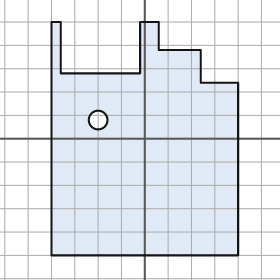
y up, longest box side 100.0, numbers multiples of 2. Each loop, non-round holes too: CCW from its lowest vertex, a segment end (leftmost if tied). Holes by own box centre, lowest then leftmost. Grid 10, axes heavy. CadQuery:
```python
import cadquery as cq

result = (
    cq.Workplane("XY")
    .moveTo(-40.0, -50.0)
    .lineTo(40.0, -50.0)
    .lineTo(40.0, 24.0)
    .lineTo(24.0, 24.0)
    .lineTo(24.0, 38.0)
    .lineTo(6.0, 38.0)
    .lineTo(6.0, 50.0)
    .lineTo(-2.0, 50.0)
    .lineTo(-2.0, 28.0)
    .lineTo(-36.0, 28.0)
    .lineTo(-36.0, 50.0)
    .lineTo(-40.0, 50.0)
    .close()
    .moveTo(-20.0, 8.0)
    .circle(4.0)
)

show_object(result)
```